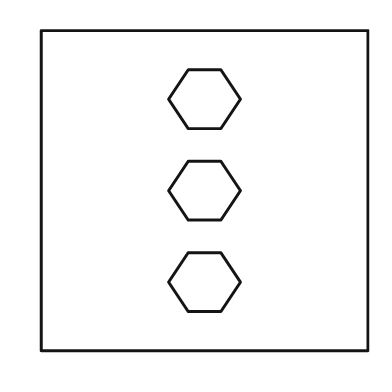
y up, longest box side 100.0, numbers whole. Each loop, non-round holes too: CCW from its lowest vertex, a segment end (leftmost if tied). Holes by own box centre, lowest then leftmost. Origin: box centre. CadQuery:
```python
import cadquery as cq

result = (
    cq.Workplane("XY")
    .moveTo(-50.0, -49.0)
    .lineTo(50.0, -49.0)
    .lineTo(50.0, 49.0)
    .lineTo(-50.0, 49.0)
    .close()
    .moveTo(-5.0, -37.0)
    .lineTo(5.0, -37.0)
    .lineTo(11.0, -28.0)
    .lineTo(5.0, -19.0)
    .lineTo(-5.0, -19.0)
    .lineTo(-11.0, -28.0)
    .close()
    .moveTo(-5.0, -9.0)
    .lineTo(5.0, -9.0)
    .lineTo(11.0, 0.0)
    .lineTo(5.0, 9.0)
    .lineTo(-5.0, 9.0)
    .lineTo(-11.0, 0.0)
    .close()
    .moveTo(-5.0, 19.0)
    .lineTo(5.0, 19.0)
    .lineTo(11.0, 28.0)
    .lineTo(5.0, 37.0)
    .lineTo(-5.0, 37.0)
    .lineTo(-11.0, 28.0)
    .close()
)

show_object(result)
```